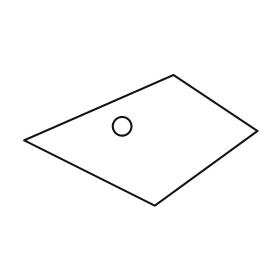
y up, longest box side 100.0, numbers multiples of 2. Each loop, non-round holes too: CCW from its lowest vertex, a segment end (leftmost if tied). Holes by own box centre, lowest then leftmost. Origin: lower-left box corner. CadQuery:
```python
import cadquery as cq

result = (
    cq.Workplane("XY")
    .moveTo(56.0, 0.0)
    .lineTo(100.0, 32.0)
    .lineTo(64.0, 56.0)
    .lineTo(0.0, 28.0)
    .close()
    .moveTo(42.0, 34.0)
    .circle(4.0)
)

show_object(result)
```